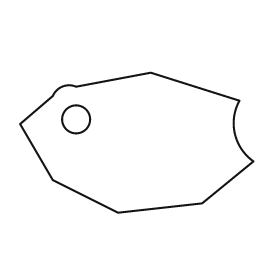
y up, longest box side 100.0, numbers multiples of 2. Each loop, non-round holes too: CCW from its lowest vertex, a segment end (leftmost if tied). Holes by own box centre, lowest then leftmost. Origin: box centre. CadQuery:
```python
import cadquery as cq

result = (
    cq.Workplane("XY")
    .moveTo(-8.0, -30.0)
    .lineTo(28.0, -26.0)
    .lineTo(50.0, -8.0)
    .threePointArc((42.0, 4.0), (44.0, 18.0))
    .lineTo(6.0, 30.0)
    .lineTo(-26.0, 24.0)
    .threePointArc((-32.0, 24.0), (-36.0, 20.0))
    .lineTo(-50.0, 8.0)
    .lineTo(-36.0, -16.0)
    .close()
    .moveTo(-26.0, 10.0)
    .circle(6.0)
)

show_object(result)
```